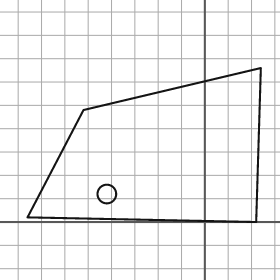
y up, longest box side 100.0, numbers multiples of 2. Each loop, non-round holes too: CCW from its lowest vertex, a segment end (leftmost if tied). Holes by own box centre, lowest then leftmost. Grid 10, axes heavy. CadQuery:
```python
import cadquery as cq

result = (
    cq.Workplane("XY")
    .moveTo(22.0, 0.0)
    .lineTo(24.0, 66.0)
    .lineTo(-52.0, 48.0)
    .lineTo(-76.0, 2.0)
    .close()
    .moveTo(-42.0, 12.0)
    .circle(4.0)
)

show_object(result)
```